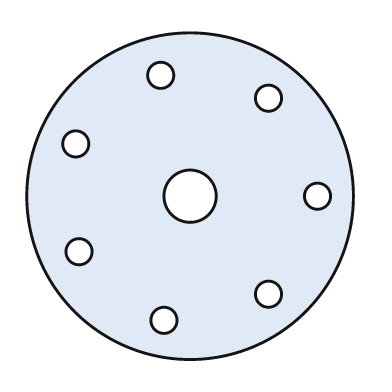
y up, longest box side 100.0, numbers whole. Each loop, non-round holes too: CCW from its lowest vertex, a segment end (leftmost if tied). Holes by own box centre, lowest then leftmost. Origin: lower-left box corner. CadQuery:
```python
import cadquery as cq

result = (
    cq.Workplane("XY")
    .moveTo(50.0, 50.0)
    .circle(50.0)
    .moveTo(42.0, 12.0)
    .circle(4.0)
    .moveTo(74.0, 20.0)
    .circle(4.0)
    .moveTo(16.0, 33.0)
    .circle(4.0)
    .moveTo(50.0, 50.0)
    .circle(8.0)
    .moveTo(89.0, 50.0)
    .circle(4.0)
    .moveTo(15.0, 66.0)
    .circle(4.0)
    .moveTo(74.0, 80.0)
    .circle(4.0)
    .moveTo(41.0, 87.0)
    .circle(4.0)
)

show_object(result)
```